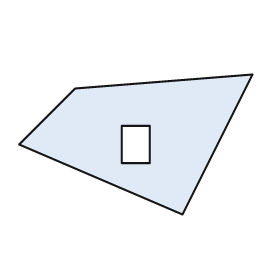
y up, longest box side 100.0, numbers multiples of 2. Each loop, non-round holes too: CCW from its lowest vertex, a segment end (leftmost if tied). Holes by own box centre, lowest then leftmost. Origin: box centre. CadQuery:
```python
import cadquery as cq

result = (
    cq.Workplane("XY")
    .moveTo(20.0, -30.0)
    .lineTo(50.0, 30.0)
    .lineTo(-26.0, 24.0)
    .lineTo(-50.0, 0.0)
    .close()
    .moveTo(-6.0, -8.0)
    .lineTo(6.0, -8.0)
    .lineTo(6.0, 8.0)
    .lineTo(-6.0, 8.0)
    .close()
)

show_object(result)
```